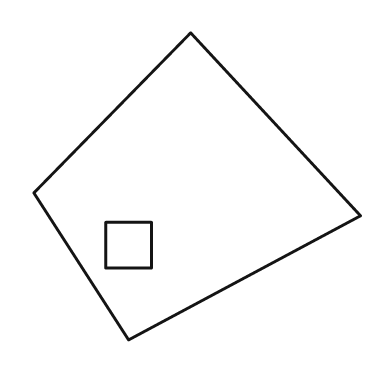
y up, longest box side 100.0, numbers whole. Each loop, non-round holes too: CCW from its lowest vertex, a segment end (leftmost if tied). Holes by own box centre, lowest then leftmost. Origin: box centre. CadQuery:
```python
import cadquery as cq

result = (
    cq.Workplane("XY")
    .moveTo(-21.0, -47.0)
    .lineTo(50.0, -9.0)
    .lineTo(-2.0, 47.0)
    .lineTo(-50.0, -2.0)
    .close()
    .moveTo(-28.0, -25.0)
    .lineTo(-14.0, -25.0)
    .lineTo(-14.0, -11.0)
    .lineTo(-28.0, -11.0)
    .close()
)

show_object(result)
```